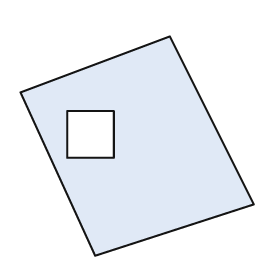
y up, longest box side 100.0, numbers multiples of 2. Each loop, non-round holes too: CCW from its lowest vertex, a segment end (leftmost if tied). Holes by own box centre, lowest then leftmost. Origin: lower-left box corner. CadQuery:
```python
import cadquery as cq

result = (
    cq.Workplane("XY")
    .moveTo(32.0, 0.0)
    .lineTo(100.0, 22.0)
    .lineTo(64.0, 94.0)
    .lineTo(0.0, 70.0)
    .close()
    .moveTo(20.0, 42.0)
    .lineTo(40.0, 42.0)
    .lineTo(40.0, 62.0)
    .lineTo(20.0, 62.0)
    .close()
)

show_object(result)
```